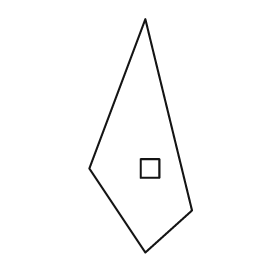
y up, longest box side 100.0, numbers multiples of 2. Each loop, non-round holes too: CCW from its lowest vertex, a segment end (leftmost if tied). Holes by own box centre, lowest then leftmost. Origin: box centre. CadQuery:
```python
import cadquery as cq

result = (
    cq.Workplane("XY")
    .moveTo(2.0, -50.0)
    .lineTo(22.0, -32.0)
    .lineTo(2.0, 50.0)
    .lineTo(-22.0, -14.0)
    .close()
    .moveTo(0.0, -18.0)
    .lineTo(8.0, -18.0)
    .lineTo(8.0, -10.0)
    .lineTo(0.0, -10.0)
    .close()
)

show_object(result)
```